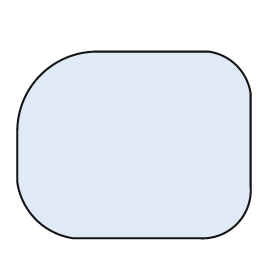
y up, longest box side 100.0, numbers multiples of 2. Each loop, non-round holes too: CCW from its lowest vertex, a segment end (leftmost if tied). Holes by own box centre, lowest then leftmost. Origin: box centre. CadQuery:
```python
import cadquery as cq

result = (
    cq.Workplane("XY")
    .moveTo(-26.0, -40.0)
    .lineTo(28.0, -40.0)
    .threePointArc((44.0, -34.0), (50.0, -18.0))
    .lineTo(50.0, 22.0)
    .threePointArc((44.0, 34.0), (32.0, 40.0))
    .lineTo(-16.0, 40.0)
    .threePointArc((-40.0, 30.0), (-50.0, 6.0))
    .lineTo(-50.0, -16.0)
    .threePointArc((-42.0, -32.0), (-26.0, -40.0))
    .close()
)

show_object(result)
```